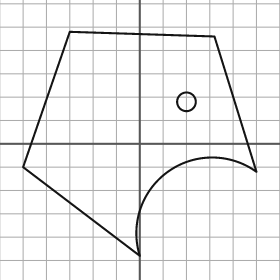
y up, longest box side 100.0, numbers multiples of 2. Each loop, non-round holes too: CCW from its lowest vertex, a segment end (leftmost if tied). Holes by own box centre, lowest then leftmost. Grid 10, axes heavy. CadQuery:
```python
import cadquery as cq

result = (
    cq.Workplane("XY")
    .moveTo(0.0, -48.0)
    .threePointArc((12.0, -12.0), (50.0, -12.0))
    .lineTo(32.0, 46.0)
    .lineTo(-30.0, 48.0)
    .lineTo(-50.0, -10.0)
    .close()
    .moveTo(20.0, 18.0)
    .circle(4.0)
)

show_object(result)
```